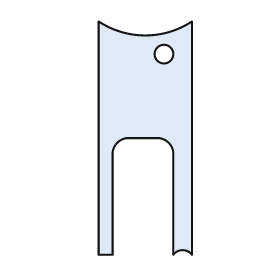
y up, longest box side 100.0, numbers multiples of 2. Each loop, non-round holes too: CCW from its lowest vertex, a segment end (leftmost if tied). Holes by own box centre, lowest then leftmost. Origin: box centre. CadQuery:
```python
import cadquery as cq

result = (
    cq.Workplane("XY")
    .moveTo(-20.0, -50.0)
    .lineTo(-14.0, -50.0)
    .lineTo(-14.0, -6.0)
    .threePointArc((-12.0, -2.0), (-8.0, 0.0))
    .lineTo(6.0, 0.0)
    .threePointArc((10.0, -2.0), (12.0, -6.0))
    .lineTo(12.0, -50.0)
    .threePointArc((16.0, -48.0), (20.0, -50.0))
    .lineTo(20.0, 50.0)
    .threePointArc((0.0, 44.0), (-20.0, 50.0))
    .close()
    .moveTo(8.0, 36.0)
    .circle(4.0)
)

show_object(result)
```